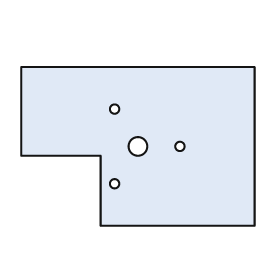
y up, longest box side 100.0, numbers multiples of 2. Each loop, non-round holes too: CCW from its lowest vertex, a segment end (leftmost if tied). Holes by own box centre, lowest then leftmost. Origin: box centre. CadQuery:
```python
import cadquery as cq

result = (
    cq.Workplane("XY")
    .moveTo(-16.0, -34.0)
    .lineTo(50.0, -34.0)
    .lineTo(50.0, 34.0)
    .lineTo(-50.0, 34.0)
    .lineTo(-50.0, -4.0)
    .lineTo(-16.0, -4.0)
    .close()
    .moveTo(-10.0, -16.0)
    .circle(2.0)
    .moveTo(0.0, 0.0)
    .circle(4.0)
    .moveTo(18.0, 0.0)
    .circle(2.0)
    .moveTo(-10.0, 16.0)
    .circle(2.0)
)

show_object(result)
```